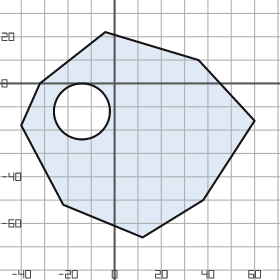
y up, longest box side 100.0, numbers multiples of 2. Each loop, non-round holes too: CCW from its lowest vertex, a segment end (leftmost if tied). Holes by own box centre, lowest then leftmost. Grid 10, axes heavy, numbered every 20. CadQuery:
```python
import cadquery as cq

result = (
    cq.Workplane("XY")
    .moveTo(12.0, -66.0)
    .lineTo(38.0, -50.0)
    .lineTo(60.0, -16.0)
    .lineTo(36.0, 10.0)
    .lineTo(-4.0, 22.0)
    .lineTo(-32.0, 0.0)
    .lineTo(-40.0, -18.0)
    .lineTo(-22.0, -52.0)
    .close()
    .moveTo(-14.0, -12.0)
    .circle(12.0)
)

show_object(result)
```